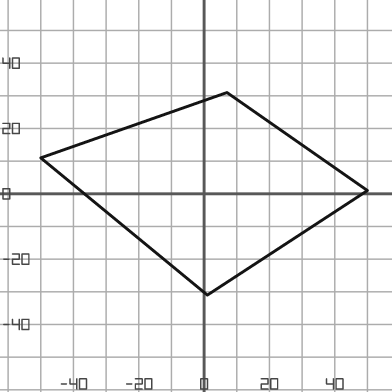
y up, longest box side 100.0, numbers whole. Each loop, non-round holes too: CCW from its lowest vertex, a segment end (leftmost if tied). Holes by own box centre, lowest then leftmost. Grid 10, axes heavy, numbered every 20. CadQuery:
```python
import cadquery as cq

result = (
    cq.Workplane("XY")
    .moveTo(1.0, -31.0)
    .lineTo(50.0, 1.0)
    .lineTo(7.0, 31.0)
    .lineTo(-50.0, 11.0)
    .close()
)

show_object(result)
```